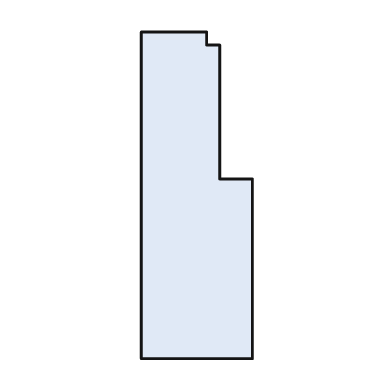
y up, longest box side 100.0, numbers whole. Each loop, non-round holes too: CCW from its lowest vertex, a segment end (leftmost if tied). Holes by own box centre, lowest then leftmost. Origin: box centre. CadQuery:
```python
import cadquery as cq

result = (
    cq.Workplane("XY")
    .moveTo(-17.0, -50.0)
    .lineTo(17.0, -50.0)
    .lineTo(17.0, 5.0)
    .lineTo(7.0, 5.0)
    .lineTo(7.0, 46.0)
    .lineTo(3.0, 46.0)
    .lineTo(3.0, 50.0)
    .lineTo(-17.0, 50.0)
    .close()
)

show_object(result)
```